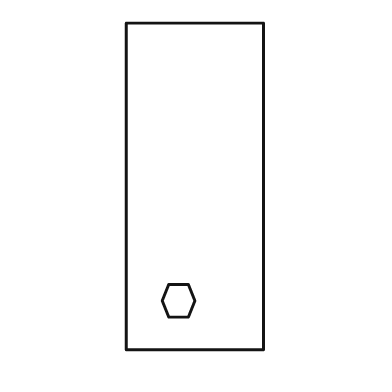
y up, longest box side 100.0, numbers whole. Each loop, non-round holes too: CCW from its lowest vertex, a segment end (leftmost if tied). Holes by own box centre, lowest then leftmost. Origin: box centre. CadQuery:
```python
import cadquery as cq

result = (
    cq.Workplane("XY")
    .moveTo(-21.0, -50.0)
    .lineTo(21.0, -50.0)
    .lineTo(21.0, 50.0)
    .lineTo(-21.0, 50.0)
    .close()
    .moveTo(-8.0, -40.0)
    .lineTo(-2.0, -40.0)
    .lineTo(0.0, -35.0)
    .lineTo(-2.0, -30.0)
    .lineTo(-8.0, -30.0)
    .lineTo(-10.0, -35.0)
    .close()
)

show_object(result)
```